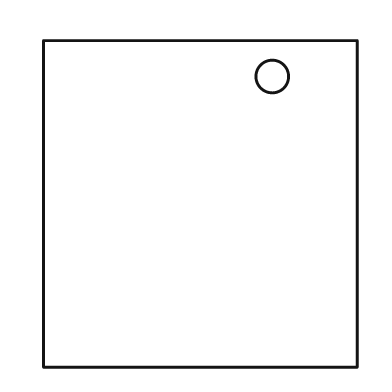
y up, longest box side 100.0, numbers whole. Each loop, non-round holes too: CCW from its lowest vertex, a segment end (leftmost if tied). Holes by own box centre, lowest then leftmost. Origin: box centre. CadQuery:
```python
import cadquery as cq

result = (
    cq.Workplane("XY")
    .moveTo(-48.0, -50.0)
    .lineTo(48.0, -50.0)
    .lineTo(48.0, 50.0)
    .lineTo(-48.0, 50.0)
    .close()
    .moveTo(22.0, 39.0)
    .circle(5.0)
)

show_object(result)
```